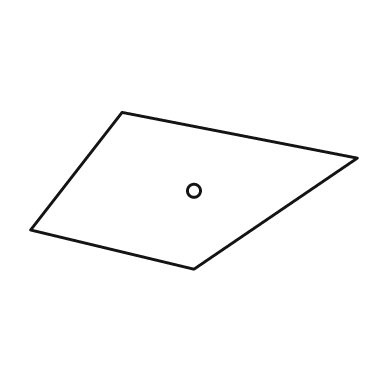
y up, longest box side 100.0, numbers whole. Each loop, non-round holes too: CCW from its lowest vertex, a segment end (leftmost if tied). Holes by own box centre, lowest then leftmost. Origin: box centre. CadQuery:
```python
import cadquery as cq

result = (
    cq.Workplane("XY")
    .moveTo(0.0, -24.0)
    .lineTo(50.0, 10.0)
    .lineTo(-22.0, 24.0)
    .lineTo(-50.0, -12.0)
    .close()
    .moveTo(0.0, 0.0)
    .circle(2.0)
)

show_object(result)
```